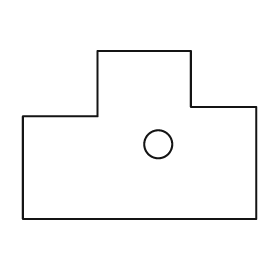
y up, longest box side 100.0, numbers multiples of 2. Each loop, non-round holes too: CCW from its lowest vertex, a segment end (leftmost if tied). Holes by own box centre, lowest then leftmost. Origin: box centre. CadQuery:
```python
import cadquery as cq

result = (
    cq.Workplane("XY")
    .moveTo(-50.0, -36.0)
    .lineTo(50.0, -36.0)
    .lineTo(50.0, 12.0)
    .lineTo(22.0, 12.0)
    .lineTo(22.0, 36.0)
    .lineTo(-18.0, 36.0)
    .lineTo(-18.0, 8.0)
    .lineTo(-50.0, 8.0)
    .close()
    .moveTo(8.0, -4.0)
    .circle(6.0)
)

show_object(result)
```